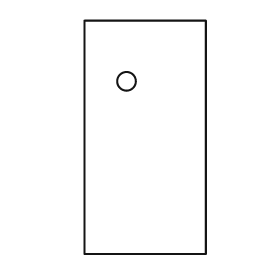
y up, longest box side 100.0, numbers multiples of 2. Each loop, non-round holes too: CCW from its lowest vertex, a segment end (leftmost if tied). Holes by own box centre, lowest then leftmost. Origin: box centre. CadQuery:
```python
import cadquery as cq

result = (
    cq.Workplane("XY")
    .moveTo(-26.0, -50.0)
    .lineTo(26.0, -50.0)
    .lineTo(26.0, 50.0)
    .lineTo(-26.0, 50.0)
    .close()
    .moveTo(-8.0, 24.0)
    .circle(4.0)
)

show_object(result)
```